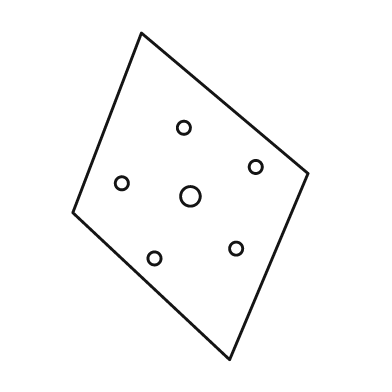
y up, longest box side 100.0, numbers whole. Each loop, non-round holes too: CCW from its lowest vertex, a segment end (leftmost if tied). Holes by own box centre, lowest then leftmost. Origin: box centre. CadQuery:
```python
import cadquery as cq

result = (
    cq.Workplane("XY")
    .moveTo(12.0, -50.0)
    .lineTo(36.0, 7.0)
    .lineTo(-15.0, 50.0)
    .lineTo(-36.0, -5.0)
    .close()
    .moveTo(-11.0, -19.0)
    .circle(2.0)
    .moveTo(14.0, -16.0)
    .circle(2.0)
    .moveTo(0.0, 0.0)
    .circle(3.0)
    .moveTo(-21.0, 4.0)
    .circle(2.0)
    .moveTo(20.0, 9.0)
    .circle(2.0)
    .moveTo(-2.0, 21.0)
    .circle(2.0)
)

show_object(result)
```